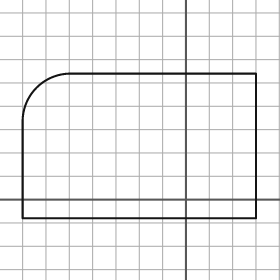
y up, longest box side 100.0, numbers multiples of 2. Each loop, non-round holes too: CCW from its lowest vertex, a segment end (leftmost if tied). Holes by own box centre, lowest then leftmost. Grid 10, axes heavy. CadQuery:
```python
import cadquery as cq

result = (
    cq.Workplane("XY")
    .moveTo(-70.0, -8.0)
    .lineTo(30.0, -8.0)
    .lineTo(30.0, 54.0)
    .lineTo(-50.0, 54.0)
    .threePointArc((-64.0, 48.0), (-70.0, 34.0))
    .close()
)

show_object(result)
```